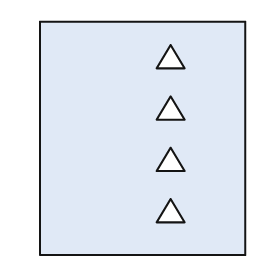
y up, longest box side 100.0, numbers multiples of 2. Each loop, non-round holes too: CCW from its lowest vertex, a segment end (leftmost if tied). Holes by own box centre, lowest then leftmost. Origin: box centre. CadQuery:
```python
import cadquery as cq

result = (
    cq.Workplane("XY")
    .moveTo(-44.0, -50.0)
    .lineTo(44.0, -50.0)
    .lineTo(44.0, 50.0)
    .lineTo(-44.0, 50.0)
    .close()
    .moveTo(6.0, -36.0)
    .lineTo(18.0, -36.0)
    .lineTo(12.0, -26.0)
    .close()
    .moveTo(6.0, -14.0)
    .lineTo(18.0, -14.0)
    .lineTo(12.0, -4.0)
    .close()
    .moveTo(6.0, 8.0)
    .lineTo(18.0, 8.0)
    .lineTo(12.0, 18.0)
    .close()
    .moveTo(6.0, 30.0)
    .lineTo(18.0, 30.0)
    .lineTo(12.0, 40.0)
    .close()
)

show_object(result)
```